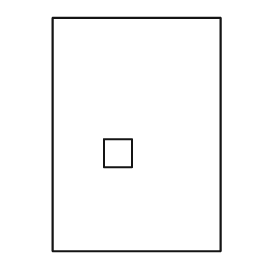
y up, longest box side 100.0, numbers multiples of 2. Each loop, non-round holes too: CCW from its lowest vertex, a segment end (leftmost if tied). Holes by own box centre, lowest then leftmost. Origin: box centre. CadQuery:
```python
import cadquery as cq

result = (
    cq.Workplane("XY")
    .moveTo(-36.0, -50.0)
    .lineTo(36.0, -50.0)
    .lineTo(36.0, 50.0)
    .lineTo(-36.0, 50.0)
    .close()
    .moveTo(-14.0, -14.0)
    .lineTo(-2.0, -14.0)
    .lineTo(-2.0, -2.0)
    .lineTo(-14.0, -2.0)
    .close()
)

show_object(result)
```